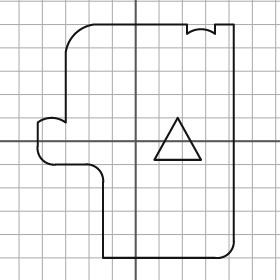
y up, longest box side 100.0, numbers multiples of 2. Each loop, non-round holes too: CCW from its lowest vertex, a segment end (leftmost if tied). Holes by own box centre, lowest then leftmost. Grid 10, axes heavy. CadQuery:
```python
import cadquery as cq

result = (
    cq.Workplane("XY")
    .moveTo(-14.0, -50.0)
    .lineTo(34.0, -50.0)
    .threePointArc((40.0, -48.0), (42.0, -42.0))
    .lineTo(42.0, 50.0)
    .lineTo(34.0, 50.0)
    .lineTo(34.0, 46.0)
    .threePointArc((28.0, 48.0), (22.0, 46.0))
    .lineTo(22.0, 50.0)
    .lineTo(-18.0, 50.0)
    .threePointArc((-26.0, 46.0), (-30.0, 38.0))
    .lineTo(-30.0, 8.0)
    .threePointArc((-36.0, 10.0), (-42.0, 8.0))
    .lineTo(-42.0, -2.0)
    .threePointArc((-40.0, -8.0), (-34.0, -10.0))
    .lineTo(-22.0, -10.0)
    .threePointArc((-16.0, -12.0), (-14.0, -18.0))
    .close()
    .moveTo(8.0, -8.0)
    .lineTo(28.0, -8.0)
    .lineTo(18.0, 10.0)
    .close()
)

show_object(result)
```